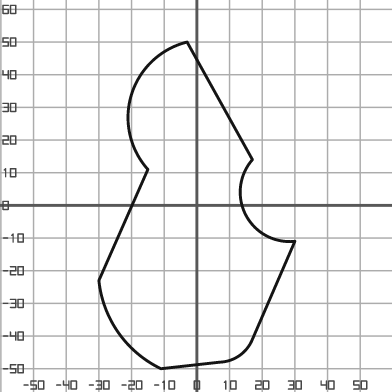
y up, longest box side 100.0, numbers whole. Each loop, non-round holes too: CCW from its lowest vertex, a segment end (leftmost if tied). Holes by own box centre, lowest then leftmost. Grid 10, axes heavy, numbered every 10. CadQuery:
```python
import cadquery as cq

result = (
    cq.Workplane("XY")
    .moveTo(-11.0, -50.0)
    .lineTo(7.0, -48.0)
    .threePointArc((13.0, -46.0), (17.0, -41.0))
    .lineTo(30.0, -11.0)
    .threePointArc((15.0, -3.0), (17.0, 14.0))
    .lineTo(-3.0, 50.0)
    .threePointArc((-20.0, 34.0), (-15.0, 11.0))
    .lineTo(-30.0, -23.0)
    .threePointArc((-24.0, -39.0), (-11.0, -50.0))
    .close()
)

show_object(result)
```